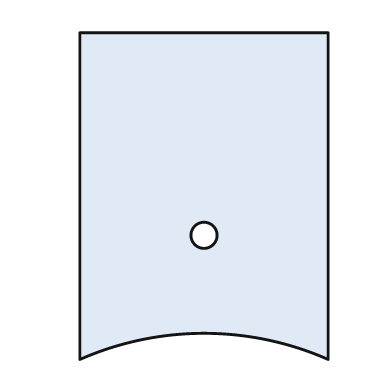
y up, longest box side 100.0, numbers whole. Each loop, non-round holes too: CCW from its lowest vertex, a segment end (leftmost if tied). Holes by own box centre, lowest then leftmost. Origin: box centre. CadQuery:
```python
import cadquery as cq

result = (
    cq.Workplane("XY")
    .moveTo(-38.0, -50.0)
    .threePointArc((0.0, -42.0), (38.0, -50.0))
    .lineTo(38.0, 50.0)
    .lineTo(-38.0, 50.0)
    .close()
    .moveTo(0.0, -12.0)
    .circle(4.0)
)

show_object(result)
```